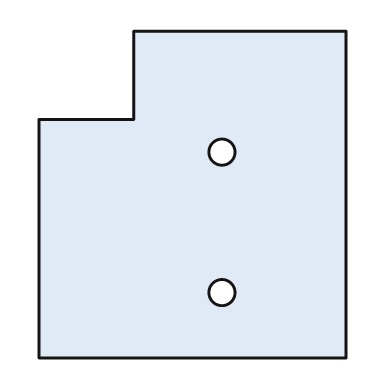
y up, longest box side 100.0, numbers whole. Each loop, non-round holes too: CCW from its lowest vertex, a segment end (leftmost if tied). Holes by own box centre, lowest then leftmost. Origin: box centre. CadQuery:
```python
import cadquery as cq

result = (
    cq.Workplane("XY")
    .moveTo(-47.0, -50.0)
    .lineTo(47.0, -50.0)
    .lineTo(47.0, 50.0)
    .lineTo(-18.0, 50.0)
    .lineTo(-18.0, 23.0)
    .lineTo(-47.0, 23.0)
    .close()
    .moveTo(9.0, -30.0)
    .circle(4.0)
    .moveTo(9.0, 13.0)
    .circle(4.0)
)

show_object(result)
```